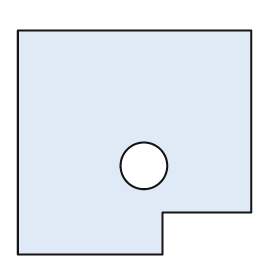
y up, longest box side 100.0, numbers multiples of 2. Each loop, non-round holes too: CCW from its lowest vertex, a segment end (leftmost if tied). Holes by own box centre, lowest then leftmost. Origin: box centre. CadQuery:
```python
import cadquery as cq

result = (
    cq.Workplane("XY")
    .moveTo(-50.0, -48.0)
    .lineTo(12.0, -48.0)
    .lineTo(12.0, -30.0)
    .lineTo(50.0, -30.0)
    .lineTo(50.0, 48.0)
    .lineTo(-50.0, 48.0)
    .close()
    .moveTo(4.0, -10.0)
    .circle(10.0)
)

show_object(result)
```